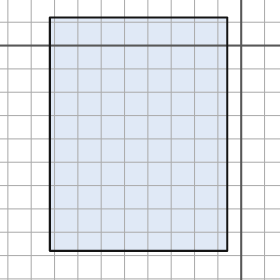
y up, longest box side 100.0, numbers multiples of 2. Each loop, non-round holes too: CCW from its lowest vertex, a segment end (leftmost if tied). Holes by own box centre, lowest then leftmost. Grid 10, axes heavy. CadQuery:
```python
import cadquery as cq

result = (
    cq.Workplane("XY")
    .moveTo(-82.0, -88.0)
    .lineTo(-6.0, -88.0)
    .lineTo(-6.0, 12.0)
    .lineTo(-82.0, 12.0)
    .close()
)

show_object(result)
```